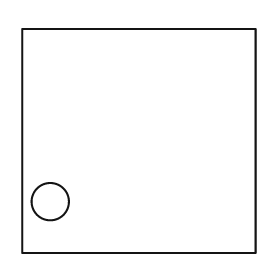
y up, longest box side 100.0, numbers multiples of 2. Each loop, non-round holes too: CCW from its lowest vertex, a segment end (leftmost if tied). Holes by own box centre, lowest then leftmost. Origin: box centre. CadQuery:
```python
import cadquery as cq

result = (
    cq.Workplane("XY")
    .moveTo(-50.0, -48.0)
    .lineTo(50.0, -48.0)
    .lineTo(50.0, 48.0)
    .lineTo(-50.0, 48.0)
    .close()
    .moveTo(-38.0, -26.0)
    .circle(8.0)
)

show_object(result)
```